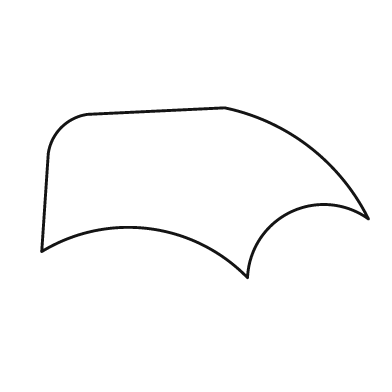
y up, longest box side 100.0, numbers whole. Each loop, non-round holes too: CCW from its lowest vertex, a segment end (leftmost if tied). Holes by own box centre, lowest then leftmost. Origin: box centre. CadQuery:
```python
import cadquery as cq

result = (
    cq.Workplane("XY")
    .moveTo(13.0, -26.0)
    .threePointArc((26.0, -6.0), (50.0, -8.0))
    .threePointArc((32.0, 14.0), (6.0, 26.0))
    .lineTo(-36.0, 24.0)
    .threePointArc((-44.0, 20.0), (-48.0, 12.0))
    .lineTo(-50.0, -18.0)
    .threePointArc((-17.0, -11.0), (13.0, -26.0))
    .close()
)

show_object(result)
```